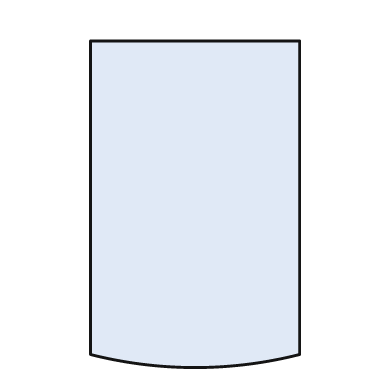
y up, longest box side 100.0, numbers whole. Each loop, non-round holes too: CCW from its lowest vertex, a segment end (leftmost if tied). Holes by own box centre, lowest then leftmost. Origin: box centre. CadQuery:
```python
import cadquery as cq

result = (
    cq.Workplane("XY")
    .moveTo(-32.0, -46.0)
    .threePointArc((0.0, -50.0), (32.0, -46.0))
    .lineTo(32.0, 50.0)
    .lineTo(-32.0, 50.0)
    .close()
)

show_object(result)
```